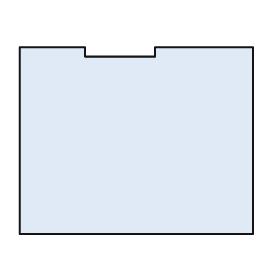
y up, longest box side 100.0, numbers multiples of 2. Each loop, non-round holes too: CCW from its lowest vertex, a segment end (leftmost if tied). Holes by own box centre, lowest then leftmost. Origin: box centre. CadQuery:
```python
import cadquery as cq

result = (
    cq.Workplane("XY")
    .moveTo(-50.0, -40.0)
    .lineTo(50.0, -40.0)
    .lineTo(50.0, 40.0)
    .lineTo(8.0, 40.0)
    .lineTo(8.0, 36.0)
    .lineTo(-22.0, 36.0)
    .lineTo(-22.0, 40.0)
    .lineTo(-50.0, 40.0)
    .close()
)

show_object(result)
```